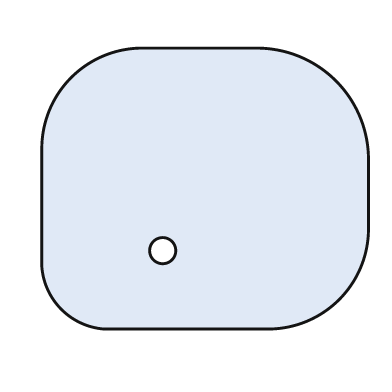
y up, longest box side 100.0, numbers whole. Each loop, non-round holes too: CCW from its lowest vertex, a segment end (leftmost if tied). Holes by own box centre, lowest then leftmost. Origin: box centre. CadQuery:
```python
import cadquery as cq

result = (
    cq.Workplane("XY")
    .moveTo(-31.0, -43.0)
    .lineTo(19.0, -43.0)
    .threePointArc((41.0, -34.0), (50.0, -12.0))
    .lineTo(50.0, 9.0)
    .threePointArc((40.0, 33.0), (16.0, 43.0))
    .lineTo(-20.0, 43.0)
    .threePointArc((-41.0, 34.0), (-50.0, 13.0))
    .lineTo(-50.0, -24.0)
    .threePointArc((-44.0, -37.0), (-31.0, -43.0))
    .close()
    .moveTo(-13.0, -19.0)
    .circle(4.0)
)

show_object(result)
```